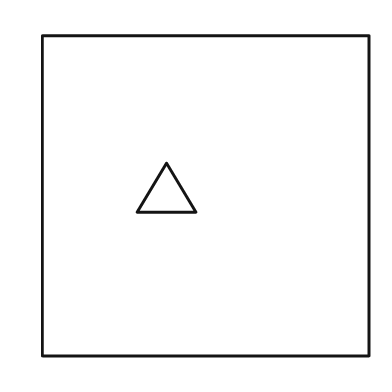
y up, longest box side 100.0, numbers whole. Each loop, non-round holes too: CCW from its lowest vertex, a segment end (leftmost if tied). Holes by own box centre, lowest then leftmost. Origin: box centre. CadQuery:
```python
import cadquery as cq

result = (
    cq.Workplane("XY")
    .moveTo(-50.0, -49.0)
    .lineTo(50.0, -49.0)
    .lineTo(50.0, 49.0)
    .lineTo(-50.0, 49.0)
    .close()
    .moveTo(-21.0, -5.0)
    .lineTo(-3.0, -5.0)
    .lineTo(-12.0, 10.0)
    .close()
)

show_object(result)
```